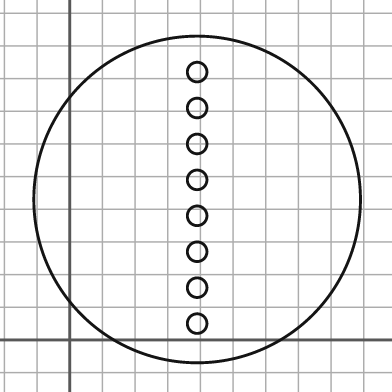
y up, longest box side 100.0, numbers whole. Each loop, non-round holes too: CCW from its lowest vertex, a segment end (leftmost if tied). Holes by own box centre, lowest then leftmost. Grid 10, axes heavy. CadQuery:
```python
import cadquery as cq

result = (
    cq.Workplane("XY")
    .moveTo(39.0, 43.0)
    .circle(50.0)
    .moveTo(39.0, 5.0)
    .circle(3.0)
    .moveTo(39.0, 16.0)
    .circle(3.0)
    .moveTo(39.0, 27.0)
    .circle(3.0)
    .moveTo(39.0, 38.0)
    .circle(3.0)
    .moveTo(39.0, 49.0)
    .circle(3.0)
    .moveTo(39.0, 60.0)
    .circle(3.0)
    .moveTo(39.0, 71.0)
    .circle(3.0)
    .moveTo(39.0, 82.0)
    .circle(3.0)
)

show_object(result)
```